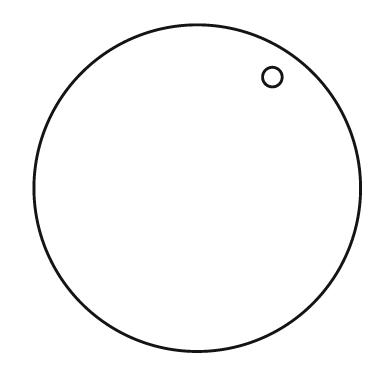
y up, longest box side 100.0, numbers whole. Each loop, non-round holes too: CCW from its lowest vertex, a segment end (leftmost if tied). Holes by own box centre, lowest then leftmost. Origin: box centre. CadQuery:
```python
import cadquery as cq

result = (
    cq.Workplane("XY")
    .moveTo(0.0, 0.0)
    .circle(50.0)
    .moveTo(23.0, 34.0)
    .circle(3.0)
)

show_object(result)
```